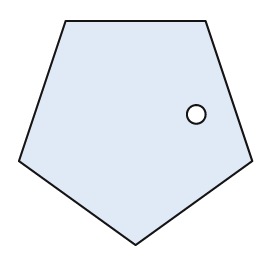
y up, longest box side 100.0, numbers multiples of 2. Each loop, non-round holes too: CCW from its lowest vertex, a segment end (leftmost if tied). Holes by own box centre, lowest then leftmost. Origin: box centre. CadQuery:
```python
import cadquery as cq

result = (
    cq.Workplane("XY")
    .moveTo(0.0, -48.0)
    .lineTo(50.0, -12.0)
    .lineTo(30.0, 48.0)
    .lineTo(-30.0, 48.0)
    .lineTo(-50.0, -12.0)
    .close()
    .moveTo(26.0, 8.0)
    .circle(4.0)
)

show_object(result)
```